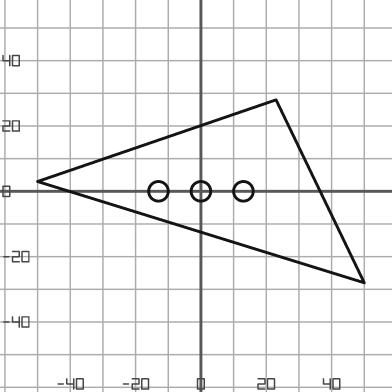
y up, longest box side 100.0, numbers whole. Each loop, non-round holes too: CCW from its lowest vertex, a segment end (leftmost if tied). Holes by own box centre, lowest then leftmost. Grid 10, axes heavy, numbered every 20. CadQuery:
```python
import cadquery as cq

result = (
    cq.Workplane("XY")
    .moveTo(50.0, -28.0)
    .lineTo(23.0, 28.0)
    .lineTo(-50.0, 3.0)
    .close()
    .moveTo(-13.0, 0.0)
    .circle(3.0)
    .moveTo(0.0, 0.0)
    .circle(3.0)
    .moveTo(13.0, 0.0)
    .circle(3.0)
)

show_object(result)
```